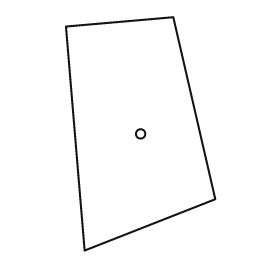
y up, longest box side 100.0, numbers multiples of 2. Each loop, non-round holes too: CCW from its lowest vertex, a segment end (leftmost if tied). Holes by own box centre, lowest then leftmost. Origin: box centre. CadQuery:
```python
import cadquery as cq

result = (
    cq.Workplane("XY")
    .moveTo(-24.0, -50.0)
    .lineTo(32.0, -28.0)
    .lineTo(14.0, 50.0)
    .lineTo(-32.0, 46.0)
    .close()
    .moveTo(0.0, 0.0)
    .circle(2.0)
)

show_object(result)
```